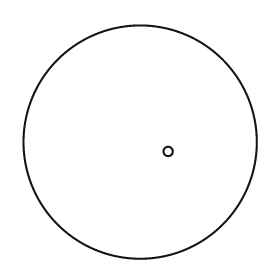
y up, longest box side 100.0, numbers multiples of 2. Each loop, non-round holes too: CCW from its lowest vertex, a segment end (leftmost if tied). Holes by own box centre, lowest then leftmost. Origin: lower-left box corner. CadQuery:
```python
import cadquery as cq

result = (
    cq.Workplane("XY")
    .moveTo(50.0, 50.0)
    .circle(50.0)
    .moveTo(62.0, 46.0)
    .circle(2.0)
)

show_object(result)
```